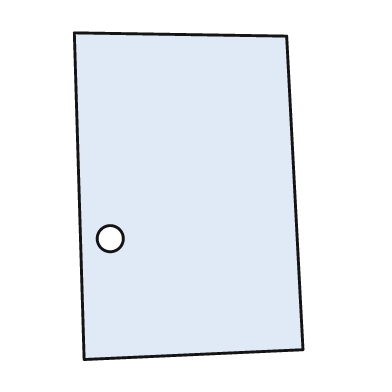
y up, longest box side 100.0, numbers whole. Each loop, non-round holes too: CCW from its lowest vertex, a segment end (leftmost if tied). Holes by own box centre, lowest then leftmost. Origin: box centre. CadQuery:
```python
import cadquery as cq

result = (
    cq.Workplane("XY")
    .moveTo(-32.0, -50.0)
    .lineTo(35.0, -47.0)
    .lineTo(30.0, 49.0)
    .lineTo(-35.0, 50.0)
    .close()
    .moveTo(-24.0, -13.0)
    .circle(4.0)
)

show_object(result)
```